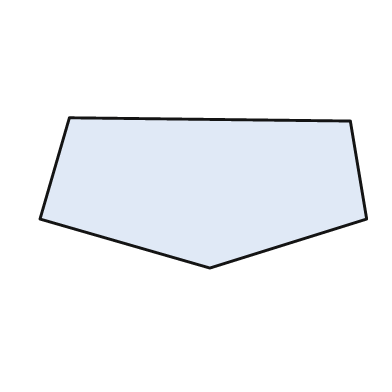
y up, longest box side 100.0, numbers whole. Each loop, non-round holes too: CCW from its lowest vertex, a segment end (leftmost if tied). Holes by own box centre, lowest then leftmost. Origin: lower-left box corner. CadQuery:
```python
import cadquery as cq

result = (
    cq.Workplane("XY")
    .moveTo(52.0, 0.0)
    .lineTo(100.0, 15.0)
    .lineTo(95.0, 45.0)
    .lineTo(9.0, 46.0)
    .lineTo(0.0, 15.0)
    .close()
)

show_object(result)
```